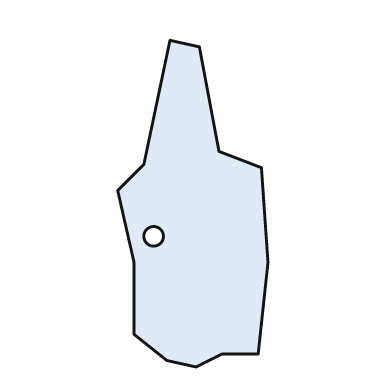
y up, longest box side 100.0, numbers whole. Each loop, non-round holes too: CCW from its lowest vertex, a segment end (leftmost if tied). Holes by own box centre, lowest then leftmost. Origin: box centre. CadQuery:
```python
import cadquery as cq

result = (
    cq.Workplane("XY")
    .moveTo(1.0, -50.0)
    .lineTo(9.0, -46.0)
    .lineTo(20.0, -46.0)
    .lineTo(23.0, -18.0)
    .lineTo(21.0, 11.0)
    .lineTo(8.0, 16.0)
    .lineTo(2.0, 48.0)
    .lineTo(-7.0, 50.0)
    .lineTo(-15.0, 12.0)
    .lineTo(-23.0, 4.0)
    .lineTo(-18.0, -18.0)
    .lineTo(-18.0, -40.0)
    .lineTo(-8.0, -48.0)
    .close()
    .moveTo(-12.0, -10.0)
    .circle(3.0)
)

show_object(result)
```